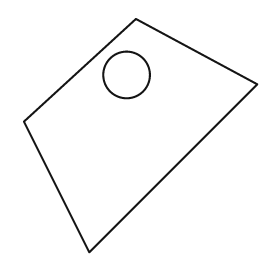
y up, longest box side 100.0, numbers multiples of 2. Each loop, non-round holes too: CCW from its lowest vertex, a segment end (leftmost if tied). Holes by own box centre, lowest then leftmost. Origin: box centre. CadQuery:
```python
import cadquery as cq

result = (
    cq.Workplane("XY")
    .moveTo(-22.0, -50.0)
    .lineTo(50.0, 22.0)
    .lineTo(-2.0, 50.0)
    .lineTo(-50.0, 6.0)
    .close()
    .moveTo(-6.0, 26.0)
    .circle(10.0)
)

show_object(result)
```